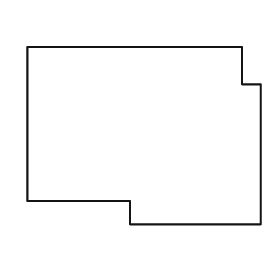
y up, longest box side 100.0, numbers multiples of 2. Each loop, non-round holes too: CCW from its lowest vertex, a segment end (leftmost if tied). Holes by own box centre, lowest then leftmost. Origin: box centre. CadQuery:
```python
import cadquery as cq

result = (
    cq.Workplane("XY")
    .moveTo(-6.0, -38.0)
    .lineTo(50.0, -38.0)
    .lineTo(50.0, 22.0)
    .lineTo(42.0, 22.0)
    .lineTo(42.0, 38.0)
    .lineTo(-50.0, 38.0)
    .lineTo(-50.0, -28.0)
    .lineTo(-6.0, -28.0)
    .close()
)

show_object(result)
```